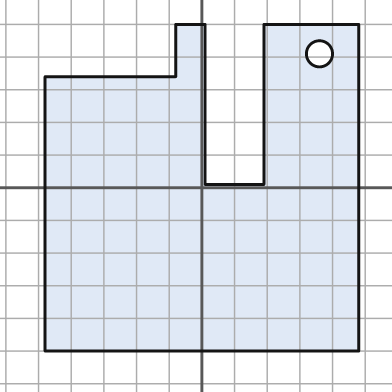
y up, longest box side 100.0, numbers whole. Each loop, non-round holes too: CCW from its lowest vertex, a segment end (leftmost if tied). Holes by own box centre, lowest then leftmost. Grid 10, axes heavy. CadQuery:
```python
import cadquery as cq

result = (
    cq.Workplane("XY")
    .moveTo(-48.0, -50.0)
    .lineTo(48.0, -50.0)
    .lineTo(48.0, 50.0)
    .lineTo(19.0, 50.0)
    .lineTo(19.0, 1.0)
    .lineTo(1.0, 1.0)
    .lineTo(1.0, 50.0)
    .lineTo(-8.0, 50.0)
    .lineTo(-8.0, 34.0)
    .lineTo(-48.0, 34.0)
    .close()
    .moveTo(36.0, 41.0)
    .circle(4.0)
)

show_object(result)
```